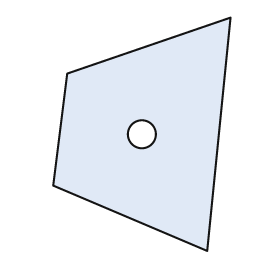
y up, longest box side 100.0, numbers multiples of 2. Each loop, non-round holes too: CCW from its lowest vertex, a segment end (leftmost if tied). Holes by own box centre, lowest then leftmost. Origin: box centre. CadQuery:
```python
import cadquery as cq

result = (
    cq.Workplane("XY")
    .moveTo(28.0, -50.0)
    .lineTo(38.0, 50.0)
    .lineTo(-32.0, 26.0)
    .lineTo(-38.0, -22.0)
    .close()
    .moveTo(0.0, 0.0)
    .circle(6.0)
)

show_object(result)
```